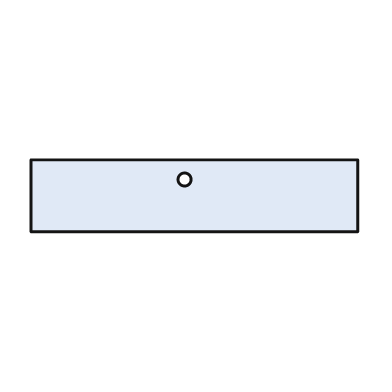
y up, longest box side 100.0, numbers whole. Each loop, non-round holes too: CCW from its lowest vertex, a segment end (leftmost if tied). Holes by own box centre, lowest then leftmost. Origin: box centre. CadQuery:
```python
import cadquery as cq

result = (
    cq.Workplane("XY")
    .moveTo(-50.0, -11.0)
    .lineTo(50.0, -11.0)
    .lineTo(50.0, 11.0)
    .lineTo(-50.0, 11.0)
    .close()
    .moveTo(-3.0, 5.0)
    .circle(2.0)
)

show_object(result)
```